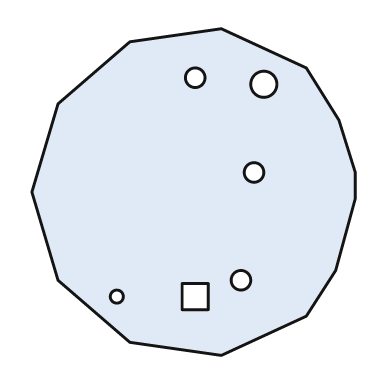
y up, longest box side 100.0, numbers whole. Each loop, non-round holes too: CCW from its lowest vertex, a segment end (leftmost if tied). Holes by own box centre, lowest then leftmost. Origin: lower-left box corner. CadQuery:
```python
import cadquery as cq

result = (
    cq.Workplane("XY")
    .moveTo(58.0, 0.0)
    .lineTo(84.0, 12.0)
    .lineTo(93.0, 26.0)
    .lineTo(99.0, 48.0)
    .lineTo(99.0, 56.0)
    .lineTo(94.0, 72.0)
    .lineTo(84.0, 88.0)
    .lineTo(58.0, 100.0)
    .lineTo(30.0, 96.0)
    .lineTo(8.0, 77.0)
    .lineTo(0.0, 50.0)
    .lineTo(8.0, 23.0)
    .lineTo(30.0, 4.0)
    .close()
    .moveTo(26.0, 18.0)
    .circle(2.0)
    .moveTo(46.0, 14.0)
    .lineTo(54.0, 14.0)
    .lineTo(54.0, 22.0)
    .lineTo(46.0, 22.0)
    .close()
    .moveTo(64.0, 23.0)
    .circle(3.0)
    .moveTo(68.0, 56.0)
    .circle(3.0)
    .moveTo(71.0, 83.0)
    .circle(4.0)
    .moveTo(50.0, 85.0)
    .circle(3.0)
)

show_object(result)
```